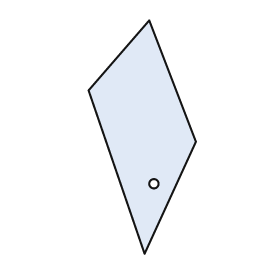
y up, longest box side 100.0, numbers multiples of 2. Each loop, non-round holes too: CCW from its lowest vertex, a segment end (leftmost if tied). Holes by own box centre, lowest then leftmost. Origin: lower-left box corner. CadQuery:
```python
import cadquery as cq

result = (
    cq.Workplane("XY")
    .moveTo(24.0, 0.0)
    .lineTo(46.0, 48.0)
    .lineTo(26.0, 100.0)
    .lineTo(0.0, 70.0)
    .close()
    .moveTo(28.0, 30.0)
    .circle(2.0)
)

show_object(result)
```